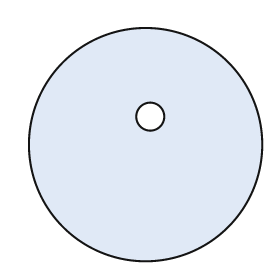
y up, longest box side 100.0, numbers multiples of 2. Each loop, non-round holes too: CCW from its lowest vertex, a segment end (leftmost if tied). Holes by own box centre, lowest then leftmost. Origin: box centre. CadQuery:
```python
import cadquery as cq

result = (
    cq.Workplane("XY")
    .moveTo(0.0, 0.0)
    .circle(50.0)
    .moveTo(2.0, 12.0)
    .circle(6.0)
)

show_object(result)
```